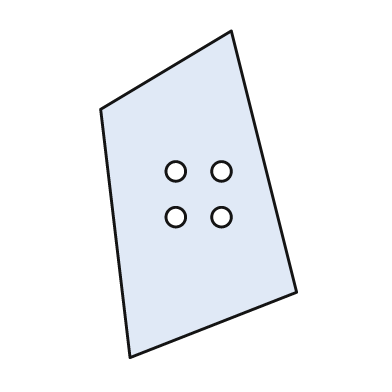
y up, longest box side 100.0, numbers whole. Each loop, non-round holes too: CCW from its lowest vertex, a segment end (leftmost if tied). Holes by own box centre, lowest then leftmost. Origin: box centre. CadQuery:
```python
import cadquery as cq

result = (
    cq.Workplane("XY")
    .moveTo(-21.0, -50.0)
    .lineTo(30.0, -30.0)
    .lineTo(10.0, 50.0)
    .lineTo(-30.0, 26.0)
    .close()
    .moveTo(-7.0, -7.0)
    .circle(3.0)
    .moveTo(7.0, -7.0)
    .circle(3.0)
    .moveTo(-7.0, 7.0)
    .circle(3.0)
    .moveTo(7.0, 7.0)
    .circle(3.0)
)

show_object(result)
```